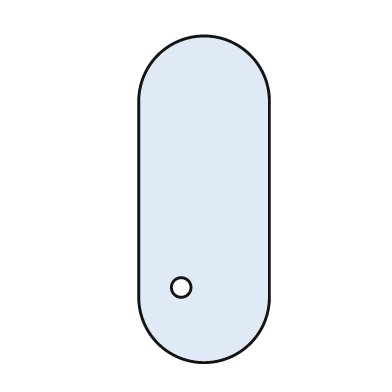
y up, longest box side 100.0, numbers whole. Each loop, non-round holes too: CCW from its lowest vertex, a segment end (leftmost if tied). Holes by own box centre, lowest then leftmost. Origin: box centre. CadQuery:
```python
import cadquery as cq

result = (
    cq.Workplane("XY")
    .moveTo(-20.0, -30.0)
    .threePointArc((0.0, -50.0), (20.0, -30.0))
    .lineTo(20.0, 30.0)
    .threePointArc((0.0, 50.0), (-20.0, 30.0))
    .close()
    .moveTo(-7.0, -27.0)
    .circle(3.0)
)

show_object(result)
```